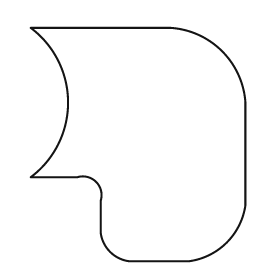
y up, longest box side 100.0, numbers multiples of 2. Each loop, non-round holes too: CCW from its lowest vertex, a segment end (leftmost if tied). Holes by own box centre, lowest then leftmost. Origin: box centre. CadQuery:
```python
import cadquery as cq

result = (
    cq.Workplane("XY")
    .moveTo(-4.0, -50.0)
    .lineTo(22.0, -50.0)
    .threePointArc((38.0, -42.0), (46.0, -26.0))
    .lineTo(46.0, 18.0)
    .threePointArc((36.0, 40.0), (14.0, 50.0))
    .lineTo(-46.0, 50.0)
    .threePointArc((-30.0, 18.0), (-46.0, -14.0))
    .lineTo(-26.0, -14.0)
    .threePointArc((-18.0, -16.0), (-16.0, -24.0))
    .lineTo(-16.0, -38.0)
    .threePointArc((-12.0, -46.0), (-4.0, -50.0))
    .close()
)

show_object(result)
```